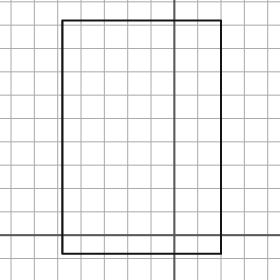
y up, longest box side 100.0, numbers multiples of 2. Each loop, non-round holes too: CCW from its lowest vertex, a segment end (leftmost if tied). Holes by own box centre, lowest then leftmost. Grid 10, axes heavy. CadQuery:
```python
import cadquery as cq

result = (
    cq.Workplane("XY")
    .moveTo(-48.0, -8.0)
    .lineTo(20.0, -8.0)
    .lineTo(20.0, 92.0)
    .lineTo(-48.0, 92.0)
    .close()
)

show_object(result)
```